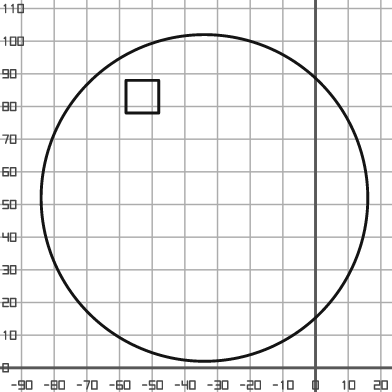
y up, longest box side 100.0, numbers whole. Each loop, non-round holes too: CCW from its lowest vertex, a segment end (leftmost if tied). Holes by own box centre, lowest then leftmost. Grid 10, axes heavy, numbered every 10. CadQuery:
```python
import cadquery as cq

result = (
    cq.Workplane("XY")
    .moveTo(-34.0, 52.0)
    .circle(50.0)
    .moveTo(-58.0, 78.0)
    .lineTo(-48.0, 78.0)
    .lineTo(-48.0, 88.0)
    .lineTo(-58.0, 88.0)
    .close()
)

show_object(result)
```